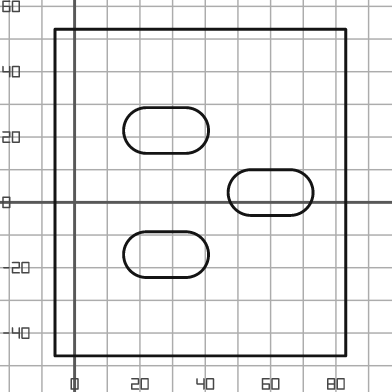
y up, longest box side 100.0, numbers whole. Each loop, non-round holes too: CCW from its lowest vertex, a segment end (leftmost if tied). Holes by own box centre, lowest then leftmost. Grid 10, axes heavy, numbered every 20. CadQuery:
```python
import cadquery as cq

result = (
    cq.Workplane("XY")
    .moveTo(-6.0, -47.0)
    .lineTo(83.0, -47.0)
    .lineTo(83.0, 53.0)
    .lineTo(-6.0, 53.0)
    .close()
    .moveTo(22.0, -23.0)
    .lineTo(34.0, -23.0)
    .threePointArc((41.0, -16.0), (34.0, -9.0))
    .lineTo(22.0, -9.0)
    .threePointArc((15.0, -16.0), (22.0, -23.0))
    .close()
    .moveTo(54.0, -4.0)
    .lineTo(66.0, -4.0)
    .threePointArc((73.0, 3.0), (66.0, 10.0))
    .lineTo(54.0, 10.0)
    .threePointArc((47.0, 3.0), (54.0, -4.0))
    .close()
    .moveTo(22.0, 15.0)
    .lineTo(34.0, 15.0)
    .threePointArc((41.0, 22.0), (34.0, 29.0))
    .lineTo(22.0, 29.0)
    .threePointArc((15.0, 22.0), (22.0, 15.0))
    .close()
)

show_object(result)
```